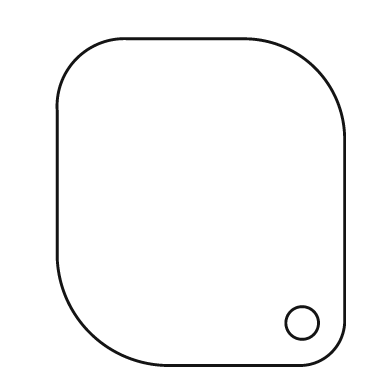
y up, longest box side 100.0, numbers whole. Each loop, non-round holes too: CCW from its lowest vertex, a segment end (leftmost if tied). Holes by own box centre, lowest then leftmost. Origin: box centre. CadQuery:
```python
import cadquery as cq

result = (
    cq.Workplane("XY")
    .moveTo(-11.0, -50.0)
    .lineTo(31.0, -50.0)
    .threePointArc((40.0, -46.0), (44.0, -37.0))
    .lineTo(44.0, 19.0)
    .threePointArc((35.0, 41.0), (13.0, 50.0))
    .lineTo(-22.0, 50.0)
    .threePointArc((-38.0, 44.0), (-44.0, 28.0))
    .lineTo(-44.0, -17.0)
    .threePointArc((-34.0, -40.0), (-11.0, -50.0))
    .close()
    .moveTo(31.0, -37.0)
    .circle(5.0)
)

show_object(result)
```